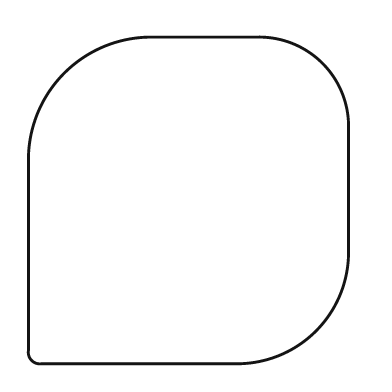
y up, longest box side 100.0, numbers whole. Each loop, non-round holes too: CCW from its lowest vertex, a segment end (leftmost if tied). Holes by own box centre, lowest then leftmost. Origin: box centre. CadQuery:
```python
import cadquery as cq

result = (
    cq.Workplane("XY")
    .moveTo(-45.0, -50.0)
    .lineTo(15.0, -50.0)
    .threePointArc((39.0, -40.0), (49.0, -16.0))
    .lineTo(49.0, 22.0)
    .threePointArc((41.0, 42.0), (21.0, 50.0))
    .lineTo(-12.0, 50.0)
    .threePointArc((-38.0, 39.0), (-49.0, 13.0))
    .lineTo(-49.0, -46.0)
    .threePointArc((-48.0, -49.0), (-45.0, -50.0))
    .close()
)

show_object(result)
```